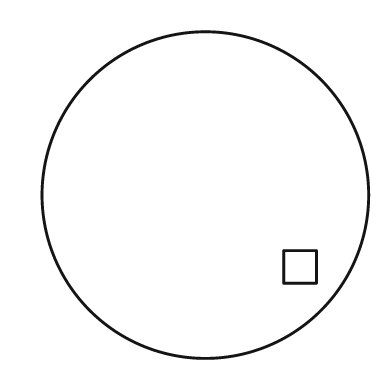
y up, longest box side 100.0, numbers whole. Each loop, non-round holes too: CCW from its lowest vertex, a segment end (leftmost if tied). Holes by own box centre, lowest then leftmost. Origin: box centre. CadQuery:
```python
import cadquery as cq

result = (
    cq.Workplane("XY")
    .moveTo(0.0, 0.0)
    .circle(50.0)
    .moveTo(24.0, -27.0)
    .lineTo(34.0, -27.0)
    .lineTo(34.0, -17.0)
    .lineTo(24.0, -17.0)
    .close()
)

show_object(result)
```